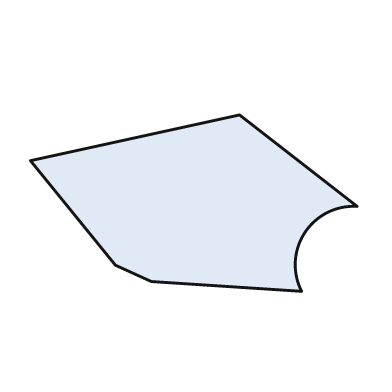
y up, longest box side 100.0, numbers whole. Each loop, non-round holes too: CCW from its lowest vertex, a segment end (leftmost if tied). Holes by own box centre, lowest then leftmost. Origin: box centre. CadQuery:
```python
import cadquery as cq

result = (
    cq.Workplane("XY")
    .moveTo(33.0, -27.0)
    .threePointArc((34.0, -9.0), (50.0, -1.0))
    .lineTo(14.0, 27.0)
    .lineTo(-50.0, 13.0)
    .lineTo(-24.0, -19.0)
    .lineTo(-13.0, -24.0)
    .close()
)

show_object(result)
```